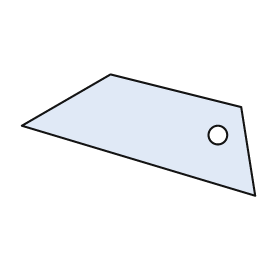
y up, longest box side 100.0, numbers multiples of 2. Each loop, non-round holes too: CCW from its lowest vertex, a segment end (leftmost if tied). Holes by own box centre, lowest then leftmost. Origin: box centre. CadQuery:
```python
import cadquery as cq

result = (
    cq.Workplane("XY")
    .moveTo(50.0, -26.0)
    .lineTo(44.0, 12.0)
    .lineTo(-12.0, 26.0)
    .lineTo(-50.0, 4.0)
    .close()
    .moveTo(34.0, 0.0)
    .circle(4.0)
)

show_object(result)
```